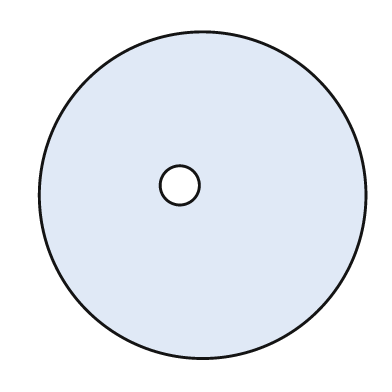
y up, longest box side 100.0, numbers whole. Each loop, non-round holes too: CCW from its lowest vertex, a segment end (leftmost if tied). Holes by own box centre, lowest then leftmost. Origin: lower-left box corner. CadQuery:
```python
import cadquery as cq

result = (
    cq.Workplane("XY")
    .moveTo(50.0, 50.0)
    .circle(50.0)
    .moveTo(43.0, 53.0)
    .circle(6.0)
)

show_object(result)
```